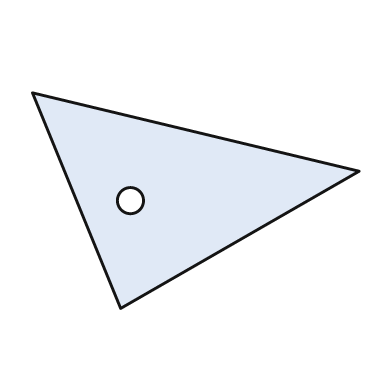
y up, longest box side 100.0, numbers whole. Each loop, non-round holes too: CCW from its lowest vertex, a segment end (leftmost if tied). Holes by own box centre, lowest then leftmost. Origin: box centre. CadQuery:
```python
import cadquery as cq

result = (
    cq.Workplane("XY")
    .moveTo(-23.0, -33.0)
    .lineTo(50.0, 9.0)
    .lineTo(-50.0, 33.0)
    .close()
    .moveTo(-20.0, 0.0)
    .circle(4.0)
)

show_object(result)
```